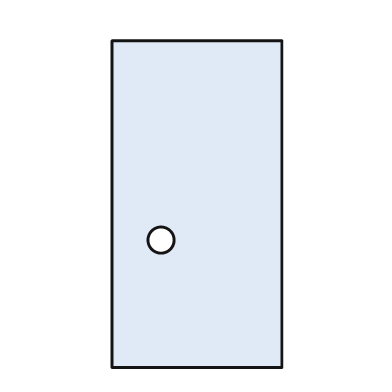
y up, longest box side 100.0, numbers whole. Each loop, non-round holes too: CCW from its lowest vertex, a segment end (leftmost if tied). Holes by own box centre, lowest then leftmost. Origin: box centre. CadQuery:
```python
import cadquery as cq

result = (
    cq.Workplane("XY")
    .moveTo(-26.0, -50.0)
    .lineTo(26.0, -50.0)
    .lineTo(26.0, 50.0)
    .lineTo(-26.0, 50.0)
    .close()
    .moveTo(-11.0, -11.0)
    .circle(4.0)
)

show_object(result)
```